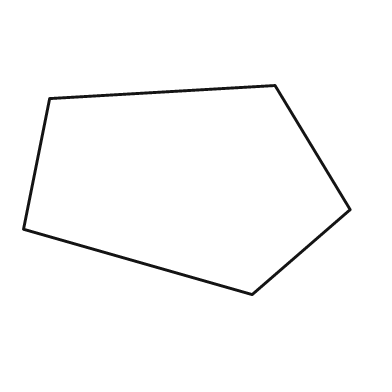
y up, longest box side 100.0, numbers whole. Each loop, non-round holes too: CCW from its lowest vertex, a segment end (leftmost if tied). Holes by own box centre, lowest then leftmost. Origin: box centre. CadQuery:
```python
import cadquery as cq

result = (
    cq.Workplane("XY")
    .moveTo(20.0, -32.0)
    .lineTo(50.0, -6.0)
    .lineTo(27.0, 32.0)
    .lineTo(-42.0, 28.0)
    .lineTo(-50.0, -12.0)
    .close()
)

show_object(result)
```